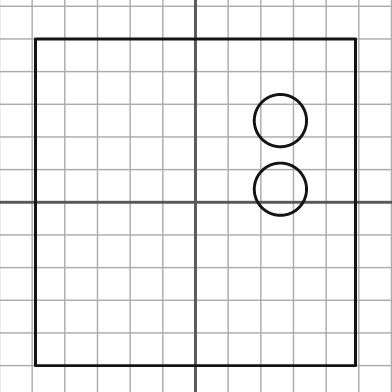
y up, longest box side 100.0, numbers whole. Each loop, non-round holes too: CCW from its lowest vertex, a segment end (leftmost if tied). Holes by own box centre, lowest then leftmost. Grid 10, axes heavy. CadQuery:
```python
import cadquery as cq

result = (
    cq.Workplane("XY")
    .moveTo(-49.0, -50.0)
    .lineTo(49.0, -50.0)
    .lineTo(49.0, 50.0)
    .lineTo(-49.0, 50.0)
    .close()
    .moveTo(26.0, 4.0)
    .circle(8.0)
    .moveTo(26.0, 25.0)
    .circle(8.0)
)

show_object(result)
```